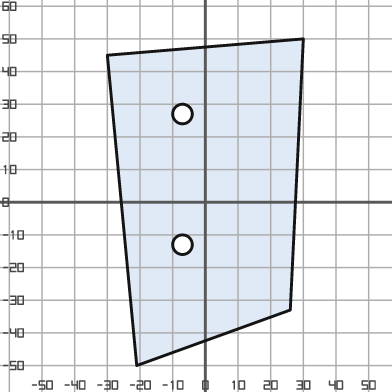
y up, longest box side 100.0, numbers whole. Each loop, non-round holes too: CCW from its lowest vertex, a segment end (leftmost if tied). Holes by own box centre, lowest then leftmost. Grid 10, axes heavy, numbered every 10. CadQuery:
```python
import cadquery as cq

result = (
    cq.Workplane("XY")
    .moveTo(-21.0, -50.0)
    .lineTo(26.0, -33.0)
    .lineTo(30.0, 50.0)
    .lineTo(-30.0, 45.0)
    .close()
    .moveTo(-7.0, -13.0)
    .circle(3.0)
    .moveTo(-7.0, 27.0)
    .circle(3.0)
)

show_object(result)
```